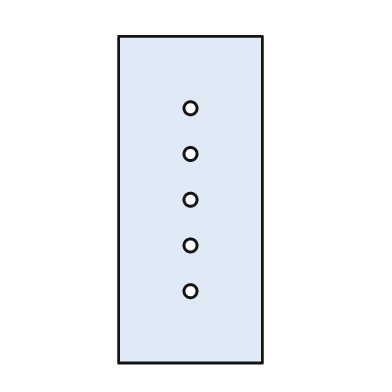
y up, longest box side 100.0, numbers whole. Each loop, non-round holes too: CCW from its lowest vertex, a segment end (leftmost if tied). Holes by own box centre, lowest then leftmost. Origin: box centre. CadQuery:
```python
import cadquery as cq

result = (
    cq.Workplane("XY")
    .moveTo(-22.0, -50.0)
    .lineTo(22.0, -50.0)
    .lineTo(22.0, 50.0)
    .lineTo(-22.0, 50.0)
    .close()
    .moveTo(0.0, -28.0)
    .circle(2.0)
    .moveTo(0.0, -14.0)
    .circle(2.0)
    .moveTo(0.0, 0.0)
    .circle(2.0)
    .moveTo(0.0, 14.0)
    .circle(2.0)
    .moveTo(0.0, 28.0)
    .circle(2.0)
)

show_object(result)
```